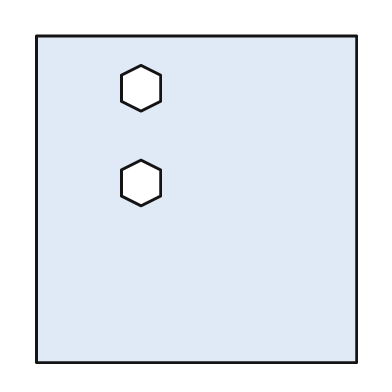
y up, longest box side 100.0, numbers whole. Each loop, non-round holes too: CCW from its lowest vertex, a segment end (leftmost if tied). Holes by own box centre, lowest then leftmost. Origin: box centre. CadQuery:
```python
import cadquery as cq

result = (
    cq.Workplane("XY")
    .moveTo(-49.0, -50.0)
    .lineTo(49.0, -50.0)
    .lineTo(49.0, 50.0)
    .lineTo(-49.0, 50.0)
    .close()
    .moveTo(-17.0, -2.0)
    .lineTo(-11.0, 1.0)
    .lineTo(-11.0, 9.0)
    .lineTo(-17.0, 12.0)
    .lineTo(-23.0, 9.0)
    .lineTo(-23.0, 1.0)
    .close()
    .moveTo(-17.0, 27.0)
    .lineTo(-11.0, 30.0)
    .lineTo(-11.0, 38.0)
    .lineTo(-17.0, 41.0)
    .lineTo(-23.0, 38.0)
    .lineTo(-23.0, 30.0)
    .close()
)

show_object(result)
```